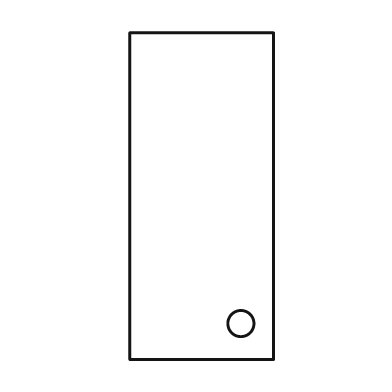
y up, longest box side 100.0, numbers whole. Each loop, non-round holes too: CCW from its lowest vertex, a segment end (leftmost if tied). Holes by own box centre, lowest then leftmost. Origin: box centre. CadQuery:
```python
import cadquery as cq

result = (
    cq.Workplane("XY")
    .moveTo(-22.0, -50.0)
    .lineTo(22.0, -50.0)
    .lineTo(22.0, 50.0)
    .lineTo(-22.0, 50.0)
    .close()
    .moveTo(12.0, -39.0)
    .circle(4.0)
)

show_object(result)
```